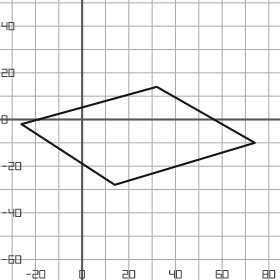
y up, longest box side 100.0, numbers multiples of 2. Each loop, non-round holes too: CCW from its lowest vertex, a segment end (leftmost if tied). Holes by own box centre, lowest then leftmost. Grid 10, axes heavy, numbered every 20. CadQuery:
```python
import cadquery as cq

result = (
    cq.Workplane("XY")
    .moveTo(14.0, -28.0)
    .lineTo(74.0, -10.0)
    .lineTo(32.0, 14.0)
    .lineTo(-26.0, -2.0)
    .close()
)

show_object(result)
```